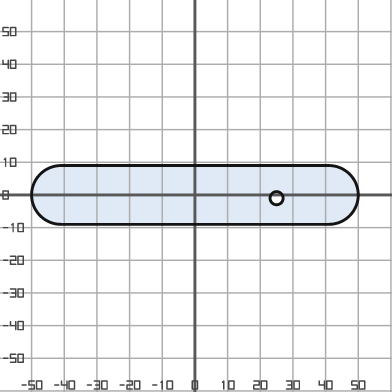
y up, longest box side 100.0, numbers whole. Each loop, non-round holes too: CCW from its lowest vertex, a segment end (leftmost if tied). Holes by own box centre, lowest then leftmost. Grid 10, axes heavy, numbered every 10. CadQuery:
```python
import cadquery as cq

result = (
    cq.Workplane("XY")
    .moveTo(-41.0, -9.0)
    .lineTo(41.0, -9.0)
    .threePointArc((50.0, 0.0), (41.0, 9.0))
    .lineTo(-41.0, 9.0)
    .threePointArc((-50.0, 0.0), (-41.0, -9.0))
    .close()
    .moveTo(25.0, -1.0)
    .circle(2.0)
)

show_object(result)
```